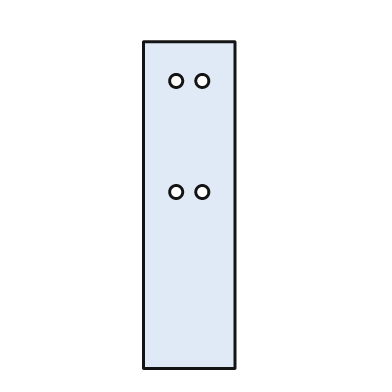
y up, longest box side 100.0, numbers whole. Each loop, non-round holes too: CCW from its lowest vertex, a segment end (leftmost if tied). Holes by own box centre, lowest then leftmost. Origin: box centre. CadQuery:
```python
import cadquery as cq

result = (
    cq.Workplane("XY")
    .moveTo(-14.0, -50.0)
    .lineTo(14.0, -50.0)
    .lineTo(14.0, 50.0)
    .lineTo(-14.0, 50.0)
    .close()
    .moveTo(-4.0, 4.0)
    .circle(2.0)
    .moveTo(4.0, 4.0)
    .circle(2.0)
    .moveTo(-4.0, 38.0)
    .circle(2.0)
    .moveTo(4.0, 38.0)
    .circle(2.0)
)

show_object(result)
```